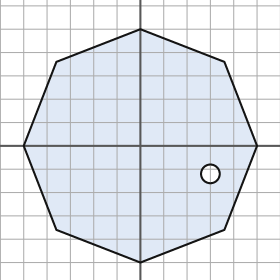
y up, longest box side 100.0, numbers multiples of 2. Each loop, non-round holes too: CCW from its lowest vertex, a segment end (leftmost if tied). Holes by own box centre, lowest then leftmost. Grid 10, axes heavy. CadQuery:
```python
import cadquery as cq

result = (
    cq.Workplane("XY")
    .moveTo(0.0, -50.0)
    .lineTo(36.0, -36.0)
    .lineTo(50.0, 0.0)
    .lineTo(36.0, 36.0)
    .lineTo(0.0, 50.0)
    .lineTo(-36.0, 36.0)
    .lineTo(-50.0, 0.0)
    .lineTo(-36.0, -36.0)
    .close()
    .moveTo(30.0, -12.0)
    .circle(4.0)
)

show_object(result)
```